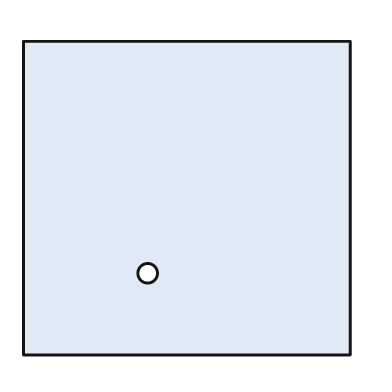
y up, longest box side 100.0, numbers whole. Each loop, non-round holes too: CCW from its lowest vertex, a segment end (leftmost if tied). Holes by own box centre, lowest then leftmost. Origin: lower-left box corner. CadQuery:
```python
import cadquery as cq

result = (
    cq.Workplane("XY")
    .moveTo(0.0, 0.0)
    .lineTo(100.0, 0.0)
    .lineTo(100.0, 96.0)
    .lineTo(0.0, 96.0)
    .close()
    .moveTo(38.0, 25.0)
    .circle(3.0)
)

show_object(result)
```